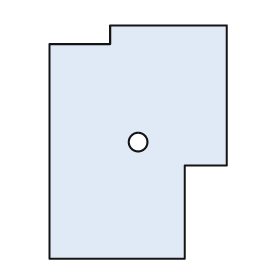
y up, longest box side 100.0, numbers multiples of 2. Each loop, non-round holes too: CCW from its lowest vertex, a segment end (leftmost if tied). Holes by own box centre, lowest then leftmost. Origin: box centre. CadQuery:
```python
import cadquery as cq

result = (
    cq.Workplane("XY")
    .moveTo(-38.0, -50.0)
    .lineTo(20.0, -50.0)
    .lineTo(20.0, -10.0)
    .lineTo(38.0, -10.0)
    .lineTo(38.0, 50.0)
    .lineTo(-12.0, 50.0)
    .lineTo(-12.0, 42.0)
    .lineTo(-38.0, 42.0)
    .close()
    .moveTo(0.0, 0.0)
    .circle(4.0)
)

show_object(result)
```